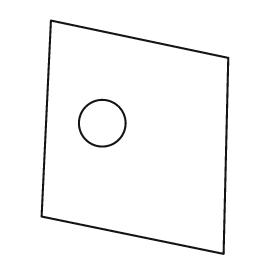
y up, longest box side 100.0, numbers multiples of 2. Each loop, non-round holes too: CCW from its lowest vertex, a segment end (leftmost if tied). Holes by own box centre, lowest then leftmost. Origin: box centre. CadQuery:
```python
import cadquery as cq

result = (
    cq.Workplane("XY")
    .moveTo(38.0, -50.0)
    .lineTo(40.0, 34.0)
    .lineTo(-36.0, 50.0)
    .lineTo(-40.0, -34.0)
    .close()
    .moveTo(-14.0, 6.0)
    .circle(10.0)
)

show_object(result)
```